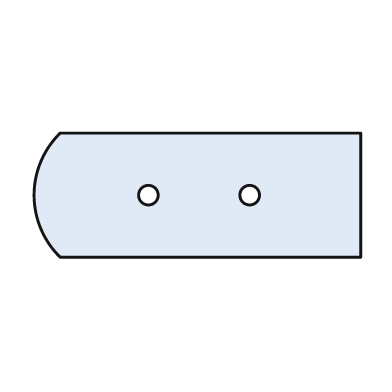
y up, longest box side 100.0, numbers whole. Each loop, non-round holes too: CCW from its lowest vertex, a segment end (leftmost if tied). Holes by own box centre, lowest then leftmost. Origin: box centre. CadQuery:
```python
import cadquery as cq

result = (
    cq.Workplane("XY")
    .moveTo(-42.0, -19.0)
    .lineTo(50.0, -19.0)
    .lineTo(50.0, 19.0)
    .lineTo(-42.0, 19.0)
    .threePointArc((-50.0, 0.0), (-42.0, -19.0))
    .close()
    .moveTo(-15.0, 0.0)
    .circle(3.0)
    .moveTo(16.0, 0.0)
    .circle(3.0)
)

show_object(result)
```